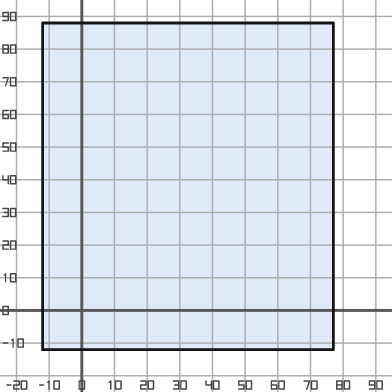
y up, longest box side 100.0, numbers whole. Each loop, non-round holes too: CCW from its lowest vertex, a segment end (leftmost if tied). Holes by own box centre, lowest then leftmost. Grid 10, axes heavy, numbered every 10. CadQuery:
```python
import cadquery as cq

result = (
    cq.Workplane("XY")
    .moveTo(-12.0, -12.0)
    .lineTo(77.0, -12.0)
    .lineTo(77.0, 88.0)
    .lineTo(-12.0, 88.0)
    .close()
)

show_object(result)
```